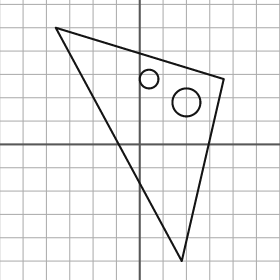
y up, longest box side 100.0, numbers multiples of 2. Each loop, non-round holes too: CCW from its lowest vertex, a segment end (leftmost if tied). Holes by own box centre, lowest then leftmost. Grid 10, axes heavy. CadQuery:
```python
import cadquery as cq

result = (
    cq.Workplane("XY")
    .moveTo(18.0, -50.0)
    .lineTo(36.0, 28.0)
    .lineTo(-36.0, 50.0)
    .close()
    .moveTo(20.0, 18.0)
    .circle(6.0)
    .moveTo(4.0, 28.0)
    .circle(4.0)
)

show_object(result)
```